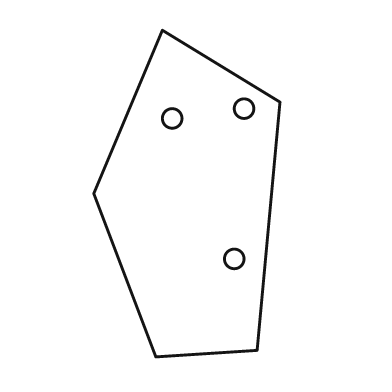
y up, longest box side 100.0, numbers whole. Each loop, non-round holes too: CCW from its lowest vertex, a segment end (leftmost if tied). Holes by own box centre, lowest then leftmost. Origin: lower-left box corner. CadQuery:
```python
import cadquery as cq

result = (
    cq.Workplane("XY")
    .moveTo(19.0, 0.0)
    .lineTo(50.0, 2.0)
    .lineTo(57.0, 78.0)
    .lineTo(21.0, 100.0)
    .lineTo(0.0, 50.0)
    .close()
    .moveTo(43.0, 30.0)
    .circle(3.0)
    .moveTo(24.0, 73.0)
    .circle(3.0)
    .moveTo(46.0, 76.0)
    .circle(3.0)
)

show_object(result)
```